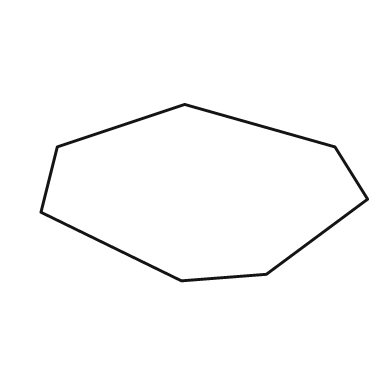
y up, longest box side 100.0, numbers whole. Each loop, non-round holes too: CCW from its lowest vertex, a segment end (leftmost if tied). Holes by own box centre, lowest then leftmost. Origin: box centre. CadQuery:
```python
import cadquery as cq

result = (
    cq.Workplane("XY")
    .moveTo(-7.0, -27.0)
    .lineTo(19.0, -25.0)
    .lineTo(50.0, -2.0)
    .lineTo(40.0, 14.0)
    .lineTo(-6.0, 27.0)
    .lineTo(-45.0, 14.0)
    .lineTo(-50.0, -6.0)
    .close()
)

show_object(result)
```